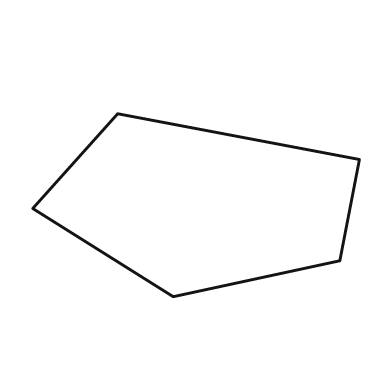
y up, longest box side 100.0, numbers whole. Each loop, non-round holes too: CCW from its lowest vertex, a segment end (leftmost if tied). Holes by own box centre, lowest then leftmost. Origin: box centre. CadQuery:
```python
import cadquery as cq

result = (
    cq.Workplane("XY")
    .moveTo(-7.0, -28.0)
    .lineTo(44.0, -17.0)
    .lineTo(50.0, 14.0)
    .lineTo(-24.0, 28.0)
    .lineTo(-50.0, -1.0)
    .close()
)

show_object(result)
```